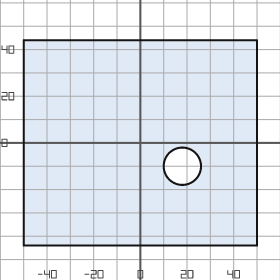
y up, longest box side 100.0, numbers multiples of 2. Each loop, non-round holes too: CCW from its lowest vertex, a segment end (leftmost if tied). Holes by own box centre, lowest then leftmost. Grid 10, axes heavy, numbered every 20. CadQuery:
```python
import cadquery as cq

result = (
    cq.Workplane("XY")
    .moveTo(-50.0, -44.0)
    .lineTo(50.0, -44.0)
    .lineTo(50.0, 44.0)
    .lineTo(-50.0, 44.0)
    .close()
    .moveTo(18.0, -10.0)
    .circle(8.0)
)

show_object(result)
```